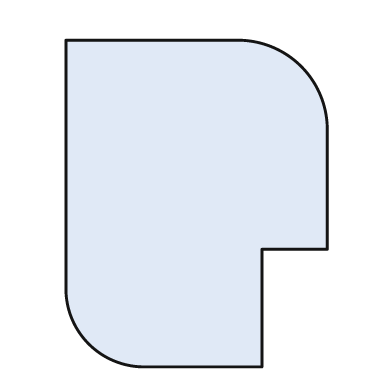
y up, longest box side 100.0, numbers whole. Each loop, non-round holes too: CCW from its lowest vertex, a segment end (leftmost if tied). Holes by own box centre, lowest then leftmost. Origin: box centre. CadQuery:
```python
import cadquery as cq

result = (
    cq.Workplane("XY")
    .moveTo(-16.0, -50.0)
    .lineTo(20.0, -50.0)
    .lineTo(20.0, -14.0)
    .lineTo(40.0, -14.0)
    .lineTo(40.0, 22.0)
    .threePointArc((32.0, 42.0), (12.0, 50.0))
    .lineTo(-40.0, 50.0)
    .lineTo(-40.0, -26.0)
    .threePointArc((-33.0, -43.0), (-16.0, -50.0))
    .close()
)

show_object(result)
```